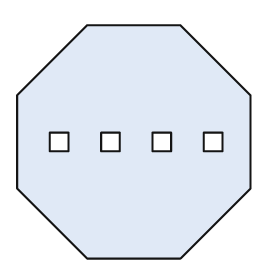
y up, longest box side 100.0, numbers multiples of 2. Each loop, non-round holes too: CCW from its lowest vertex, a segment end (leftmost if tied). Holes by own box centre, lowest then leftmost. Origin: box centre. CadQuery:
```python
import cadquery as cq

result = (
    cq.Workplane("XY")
    .moveTo(-20.0, -50.0)
    .lineTo(20.0, -50.0)
    .lineTo(50.0, -20.0)
    .lineTo(50.0, 20.0)
    .lineTo(20.0, 50.0)
    .lineTo(-20.0, 50.0)
    .lineTo(-50.0, 20.0)
    .lineTo(-50.0, -20.0)
    .close()
    .moveTo(-36.0, -4.0)
    .lineTo(-28.0, -4.0)
    .lineTo(-28.0, 4.0)
    .lineTo(-36.0, 4.0)
    .close()
    .moveTo(-14.0, -4.0)
    .lineTo(-6.0, -4.0)
    .lineTo(-6.0, 4.0)
    .lineTo(-14.0, 4.0)
    .close()
    .moveTo(8.0, -4.0)
    .lineTo(16.0, -4.0)
    .lineTo(16.0, 4.0)
    .lineTo(8.0, 4.0)
    .close()
    .moveTo(30.0, -4.0)
    .lineTo(38.0, -4.0)
    .lineTo(38.0, 4.0)
    .lineTo(30.0, 4.0)
    .close()
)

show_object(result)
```